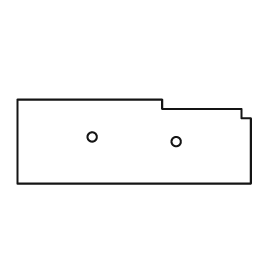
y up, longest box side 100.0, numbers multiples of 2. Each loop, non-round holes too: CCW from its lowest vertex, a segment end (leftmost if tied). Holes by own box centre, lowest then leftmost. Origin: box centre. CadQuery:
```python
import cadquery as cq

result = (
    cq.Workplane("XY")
    .moveTo(-50.0, -18.0)
    .lineTo(50.0, -18.0)
    .lineTo(50.0, 10.0)
    .lineTo(46.0, 10.0)
    .lineTo(46.0, 14.0)
    .lineTo(12.0, 14.0)
    .lineTo(12.0, 18.0)
    .lineTo(-50.0, 18.0)
    .close()
    .moveTo(18.0, 0.0)
    .circle(2.0)
    .moveTo(-18.0, 2.0)
    .circle(2.0)
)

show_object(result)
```